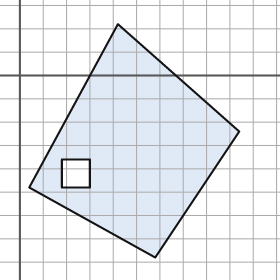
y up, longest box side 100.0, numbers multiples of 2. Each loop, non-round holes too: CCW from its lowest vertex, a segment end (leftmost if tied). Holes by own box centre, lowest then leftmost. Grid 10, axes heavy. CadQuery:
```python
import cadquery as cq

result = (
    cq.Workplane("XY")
    .moveTo(58.0, -78.0)
    .lineTo(94.0, -24.0)
    .lineTo(42.0, 22.0)
    .lineTo(4.0, -48.0)
    .close()
    .moveTo(18.0, -48.0)
    .lineTo(30.0, -48.0)
    .lineTo(30.0, -36.0)
    .lineTo(18.0, -36.0)
    .close()
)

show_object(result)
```